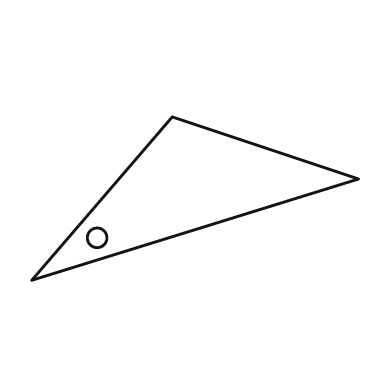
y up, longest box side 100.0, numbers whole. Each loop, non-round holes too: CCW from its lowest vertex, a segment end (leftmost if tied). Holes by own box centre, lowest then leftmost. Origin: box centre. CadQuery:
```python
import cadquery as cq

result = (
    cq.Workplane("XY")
    .moveTo(-50.0, -25.0)
    .lineTo(50.0, 6.0)
    .lineTo(-7.0, 25.0)
    .close()
    .moveTo(-30.0, -12.0)
    .circle(3.0)
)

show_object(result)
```